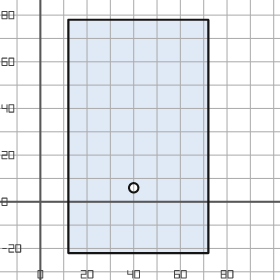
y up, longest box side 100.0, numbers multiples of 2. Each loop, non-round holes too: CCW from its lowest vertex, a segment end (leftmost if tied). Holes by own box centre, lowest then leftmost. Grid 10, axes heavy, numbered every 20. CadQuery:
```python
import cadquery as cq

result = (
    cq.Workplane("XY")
    .moveTo(12.0, -22.0)
    .lineTo(72.0, -22.0)
    .lineTo(72.0, 78.0)
    .lineTo(12.0, 78.0)
    .close()
    .moveTo(40.0, 6.0)
    .circle(2.0)
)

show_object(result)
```